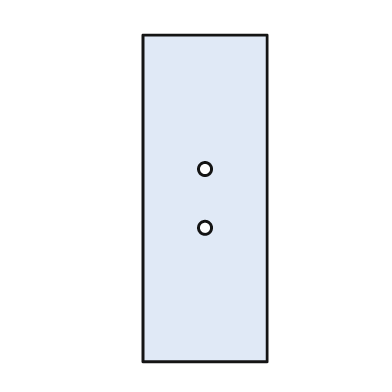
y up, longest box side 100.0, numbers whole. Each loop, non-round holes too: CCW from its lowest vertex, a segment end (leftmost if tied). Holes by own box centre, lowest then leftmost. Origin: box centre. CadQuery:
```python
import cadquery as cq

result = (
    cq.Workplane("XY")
    .moveTo(-19.0, -50.0)
    .lineTo(19.0, -50.0)
    .lineTo(19.0, 50.0)
    .lineTo(-19.0, 50.0)
    .close()
    .moveTo(0.0, -9.0)
    .circle(2.0)
    .moveTo(0.0, 9.0)
    .circle(2.0)
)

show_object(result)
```